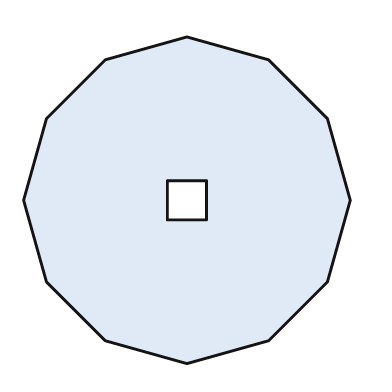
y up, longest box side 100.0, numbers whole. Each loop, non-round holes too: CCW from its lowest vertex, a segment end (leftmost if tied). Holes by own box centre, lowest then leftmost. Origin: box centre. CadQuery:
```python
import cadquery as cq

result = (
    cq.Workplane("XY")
    .moveTo(0.0, -50.0)
    .lineTo(25.0, -43.0)
    .lineTo(43.0, -25.0)
    .lineTo(50.0, 0.0)
    .lineTo(43.0, 25.0)
    .lineTo(25.0, 43.0)
    .lineTo(0.0, 50.0)
    .lineTo(-25.0, 43.0)
    .lineTo(-43.0, 25.0)
    .lineTo(-50.0, 0.0)
    .lineTo(-43.0, -25.0)
    .lineTo(-25.0, -43.0)
    .close()
    .moveTo(-6.0, -6.0)
    .lineTo(6.0, -6.0)
    .lineTo(6.0, 6.0)
    .lineTo(-6.0, 6.0)
    .close()
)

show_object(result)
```